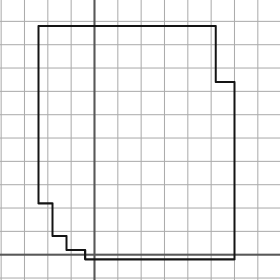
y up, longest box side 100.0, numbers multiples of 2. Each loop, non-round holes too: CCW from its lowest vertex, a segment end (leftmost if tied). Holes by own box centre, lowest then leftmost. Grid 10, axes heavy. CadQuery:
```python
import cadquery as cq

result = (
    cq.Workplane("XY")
    .moveTo(-4.0, -2.0)
    .lineTo(60.0, -2.0)
    .lineTo(60.0, 74.0)
    .lineTo(52.0, 74.0)
    .lineTo(52.0, 98.0)
    .lineTo(-24.0, 98.0)
    .lineTo(-24.0, 22.0)
    .lineTo(-18.0, 22.0)
    .lineTo(-18.0, 8.0)
    .lineTo(-12.0, 8.0)
    .lineTo(-12.0, 2.0)
    .lineTo(-4.0, 2.0)
    .close()
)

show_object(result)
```